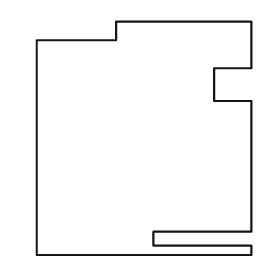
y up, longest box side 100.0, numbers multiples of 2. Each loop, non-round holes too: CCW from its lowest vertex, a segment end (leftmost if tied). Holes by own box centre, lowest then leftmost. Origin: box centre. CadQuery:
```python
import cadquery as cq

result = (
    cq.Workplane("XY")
    .moveTo(-46.0, -50.0)
    .lineTo(46.0, -50.0)
    .lineTo(46.0, -46.0)
    .lineTo(4.0, -46.0)
    .lineTo(4.0, -40.0)
    .lineTo(46.0, -40.0)
    .lineTo(46.0, 16.0)
    .lineTo(30.0, 16.0)
    .lineTo(30.0, 30.0)
    .lineTo(46.0, 30.0)
    .lineTo(46.0, 50.0)
    .lineTo(-12.0, 50.0)
    .lineTo(-12.0, 42.0)
    .lineTo(-46.0, 42.0)
    .close()
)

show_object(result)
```